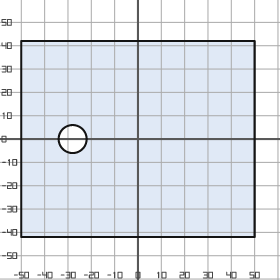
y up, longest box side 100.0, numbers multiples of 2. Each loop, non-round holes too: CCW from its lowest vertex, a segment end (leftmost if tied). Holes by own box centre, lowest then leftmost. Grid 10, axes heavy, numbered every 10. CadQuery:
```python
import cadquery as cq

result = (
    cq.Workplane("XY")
    .moveTo(-50.0, -42.0)
    .lineTo(50.0, -42.0)
    .lineTo(50.0, 42.0)
    .lineTo(-50.0, 42.0)
    .close()
    .moveTo(-28.0, 0.0)
    .circle(6.0)
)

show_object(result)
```